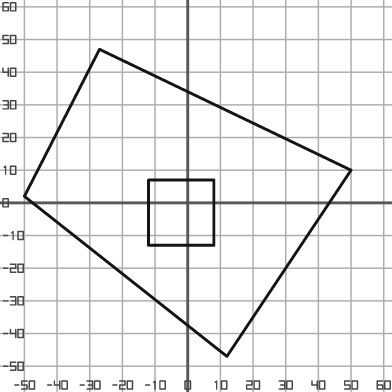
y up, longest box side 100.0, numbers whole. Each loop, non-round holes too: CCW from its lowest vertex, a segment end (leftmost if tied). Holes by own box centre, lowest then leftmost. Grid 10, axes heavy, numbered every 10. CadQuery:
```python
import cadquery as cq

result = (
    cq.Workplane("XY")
    .moveTo(12.0, -47.0)
    .lineTo(50.0, 10.0)
    .lineTo(-27.0, 47.0)
    .lineTo(-50.0, 2.0)
    .close()
    .moveTo(-12.0, -13.0)
    .lineTo(8.0, -13.0)
    .lineTo(8.0, 7.0)
    .lineTo(-12.0, 7.0)
    .close()
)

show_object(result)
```